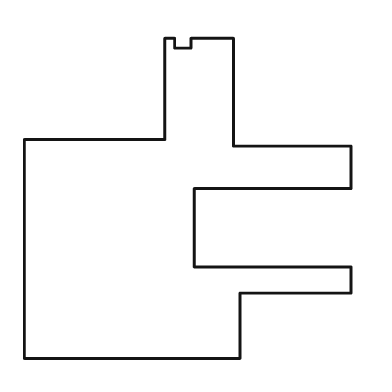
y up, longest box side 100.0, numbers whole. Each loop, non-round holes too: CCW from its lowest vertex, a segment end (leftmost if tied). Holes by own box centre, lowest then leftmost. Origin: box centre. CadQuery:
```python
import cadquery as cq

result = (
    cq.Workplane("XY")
    .moveTo(-50.0, -49.0)
    .lineTo(16.0, -49.0)
    .lineTo(16.0, -29.0)
    .lineTo(50.0, -29.0)
    .lineTo(50.0, -21.0)
    .lineTo(2.0, -21.0)
    .lineTo(2.0, 3.0)
    .lineTo(50.0, 3.0)
    .lineTo(50.0, 16.0)
    .lineTo(14.0, 16.0)
    .lineTo(14.0, 49.0)
    .lineTo(1.0, 49.0)
    .lineTo(1.0, 46.0)
    .lineTo(-4.0, 46.0)
    .lineTo(-4.0, 49.0)
    .lineTo(-7.0, 49.0)
    .lineTo(-7.0, 18.0)
    .lineTo(-50.0, 18.0)
    .close()
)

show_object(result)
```